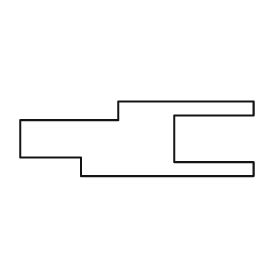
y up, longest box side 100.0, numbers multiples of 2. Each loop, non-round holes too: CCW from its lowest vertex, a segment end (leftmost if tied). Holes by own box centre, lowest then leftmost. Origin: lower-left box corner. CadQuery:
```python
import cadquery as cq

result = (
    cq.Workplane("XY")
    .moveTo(26.0, 0.0)
    .lineTo(100.0, 0.0)
    .lineTo(100.0, 6.0)
    .lineTo(66.0, 6.0)
    .lineTo(66.0, 26.0)
    .lineTo(100.0, 26.0)
    .lineTo(100.0, 32.0)
    .lineTo(42.0, 32.0)
    .lineTo(42.0, 24.0)
    .lineTo(0.0, 24.0)
    .lineTo(0.0, 8.0)
    .lineTo(26.0, 8.0)
    .close()
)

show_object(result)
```